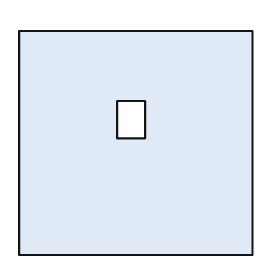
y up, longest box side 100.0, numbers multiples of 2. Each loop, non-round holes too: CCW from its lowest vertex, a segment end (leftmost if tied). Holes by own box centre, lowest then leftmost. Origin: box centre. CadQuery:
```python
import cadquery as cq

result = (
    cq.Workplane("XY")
    .moveTo(-50.0, -48.0)
    .lineTo(50.0, -48.0)
    .lineTo(50.0, 48.0)
    .lineTo(-50.0, 48.0)
    .close()
    .moveTo(-8.0, 2.0)
    .lineTo(4.0, 2.0)
    .lineTo(4.0, 18.0)
    .lineTo(-8.0, 18.0)
    .close()
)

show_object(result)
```